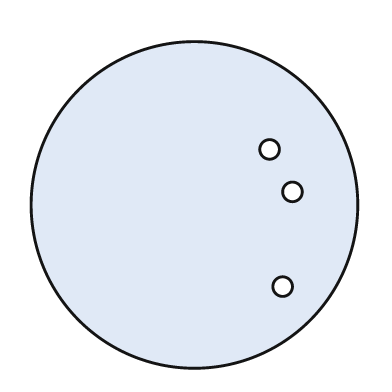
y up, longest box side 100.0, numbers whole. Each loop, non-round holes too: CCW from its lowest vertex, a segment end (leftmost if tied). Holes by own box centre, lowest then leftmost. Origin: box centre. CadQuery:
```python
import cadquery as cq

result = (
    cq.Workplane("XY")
    .moveTo(0.0, 0.0)
    .circle(50.0)
    .moveTo(27.0, -25.0)
    .circle(3.0)
    .moveTo(30.0, 4.0)
    .circle(3.0)
    .moveTo(23.0, 17.0)
    .circle(3.0)
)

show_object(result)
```